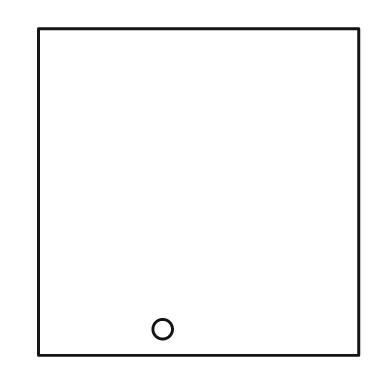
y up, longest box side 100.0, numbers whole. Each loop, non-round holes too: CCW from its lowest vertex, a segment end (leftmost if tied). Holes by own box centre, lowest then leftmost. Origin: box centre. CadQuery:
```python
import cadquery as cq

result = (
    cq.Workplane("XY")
    .moveTo(-49.0, -50.0)
    .lineTo(49.0, -50.0)
    .lineTo(49.0, 50.0)
    .lineTo(-49.0, 50.0)
    .close()
    .moveTo(-11.0, -42.0)
    .circle(3.0)
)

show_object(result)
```